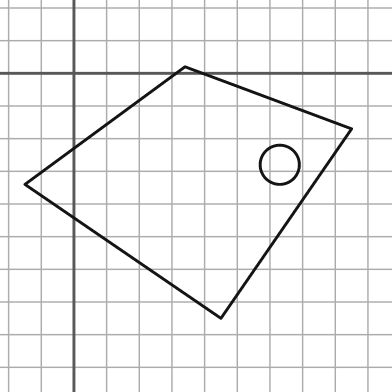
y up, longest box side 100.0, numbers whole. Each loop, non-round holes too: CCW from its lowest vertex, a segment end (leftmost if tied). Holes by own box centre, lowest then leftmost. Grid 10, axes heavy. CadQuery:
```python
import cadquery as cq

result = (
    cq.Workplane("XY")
    .moveTo(45.0, -75.0)
    .lineTo(85.0, -17.0)
    .lineTo(34.0, 2.0)
    .lineTo(-15.0, -34.0)
    .close()
    .moveTo(63.0, -28.0)
    .circle(6.0)
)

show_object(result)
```